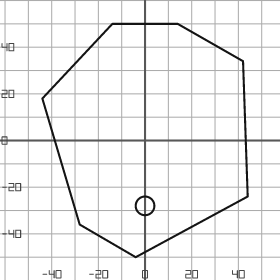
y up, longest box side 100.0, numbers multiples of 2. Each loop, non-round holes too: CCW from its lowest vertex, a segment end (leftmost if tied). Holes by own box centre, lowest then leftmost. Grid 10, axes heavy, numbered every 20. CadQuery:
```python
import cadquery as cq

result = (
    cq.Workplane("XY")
    .moveTo(-4.0, -50.0)
    .lineTo(44.0, -24.0)
    .lineTo(42.0, 34.0)
    .lineTo(14.0, 50.0)
    .lineTo(-14.0, 50.0)
    .lineTo(-44.0, 18.0)
    .lineTo(-28.0, -36.0)
    .close()
    .moveTo(0.0, -28.0)
    .circle(4.0)
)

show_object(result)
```